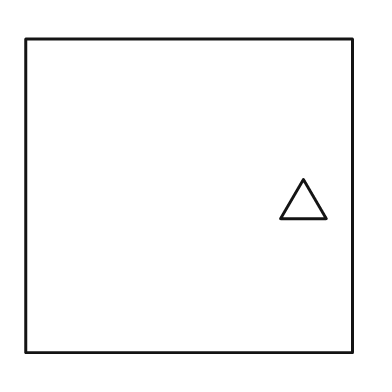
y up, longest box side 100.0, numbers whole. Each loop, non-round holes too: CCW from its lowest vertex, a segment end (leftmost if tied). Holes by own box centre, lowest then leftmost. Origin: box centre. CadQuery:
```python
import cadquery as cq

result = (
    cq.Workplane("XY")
    .moveTo(-50.0, -48.0)
    .lineTo(50.0, -48.0)
    .lineTo(50.0, 48.0)
    .lineTo(-50.0, 48.0)
    .close()
    .moveTo(28.0, -7.0)
    .lineTo(42.0, -7.0)
    .lineTo(35.0, 5.0)
    .close()
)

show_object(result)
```